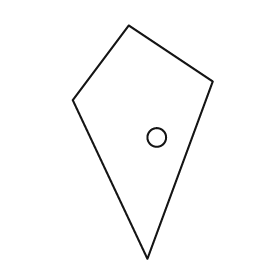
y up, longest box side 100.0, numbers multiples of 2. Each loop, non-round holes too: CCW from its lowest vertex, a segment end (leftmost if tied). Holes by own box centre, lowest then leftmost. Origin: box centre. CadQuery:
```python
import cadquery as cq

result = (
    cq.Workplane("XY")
    .moveTo(2.0, -50.0)
    .lineTo(30.0, 26.0)
    .lineTo(-6.0, 50.0)
    .lineTo(-30.0, 18.0)
    .close()
    .moveTo(6.0, 2.0)
    .circle(4.0)
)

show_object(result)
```